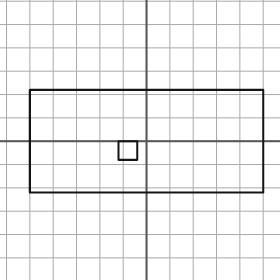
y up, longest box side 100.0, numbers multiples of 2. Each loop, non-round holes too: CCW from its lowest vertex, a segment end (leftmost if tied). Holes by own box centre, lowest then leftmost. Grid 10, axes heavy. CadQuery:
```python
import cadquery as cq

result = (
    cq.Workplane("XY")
    .moveTo(-50.0, -22.0)
    .lineTo(50.0, -22.0)
    .lineTo(50.0, 22.0)
    .lineTo(-50.0, 22.0)
    .close()
    .moveTo(-12.0, -8.0)
    .lineTo(-4.0, -8.0)
    .lineTo(-4.0, 0.0)
    .lineTo(-12.0, 0.0)
    .close()
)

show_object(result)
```